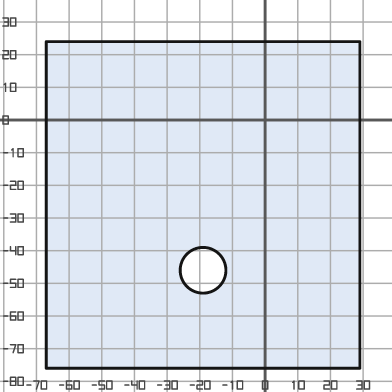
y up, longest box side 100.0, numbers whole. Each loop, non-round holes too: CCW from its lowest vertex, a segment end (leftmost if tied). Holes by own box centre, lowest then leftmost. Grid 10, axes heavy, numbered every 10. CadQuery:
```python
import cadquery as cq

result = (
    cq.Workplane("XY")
    .moveTo(-67.0, -76.0)
    .lineTo(29.0, -76.0)
    .lineTo(29.0, 24.0)
    .lineTo(-67.0, 24.0)
    .close()
    .moveTo(-19.0, -46.0)
    .circle(7.0)
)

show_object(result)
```